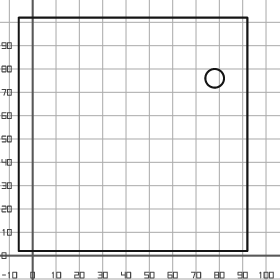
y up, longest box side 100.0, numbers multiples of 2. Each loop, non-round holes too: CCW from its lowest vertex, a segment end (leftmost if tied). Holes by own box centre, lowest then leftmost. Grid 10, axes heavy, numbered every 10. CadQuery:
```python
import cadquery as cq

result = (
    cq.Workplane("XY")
    .moveTo(-6.0, 2.0)
    .lineTo(92.0, 2.0)
    .lineTo(92.0, 102.0)
    .lineTo(-6.0, 102.0)
    .close()
    .moveTo(78.0, 76.0)
    .circle(4.0)
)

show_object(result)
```